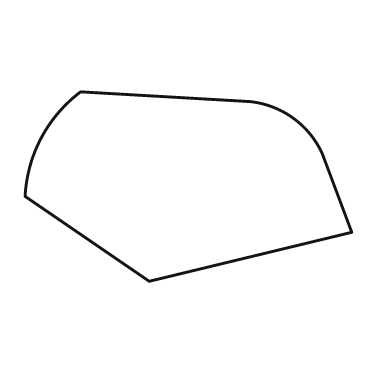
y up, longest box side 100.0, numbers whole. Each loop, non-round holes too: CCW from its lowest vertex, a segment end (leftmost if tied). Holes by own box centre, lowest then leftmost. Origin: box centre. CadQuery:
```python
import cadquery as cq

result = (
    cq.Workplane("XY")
    .moveTo(-12.0, -29.0)
    .lineTo(50.0, -14.0)
    .lineTo(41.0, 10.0)
    .threePointArc((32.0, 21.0), (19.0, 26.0))
    .lineTo(-33.0, 29.0)
    .threePointArc((-45.0, 15.0), (-50.0, -3.0))
    .close()
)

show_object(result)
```